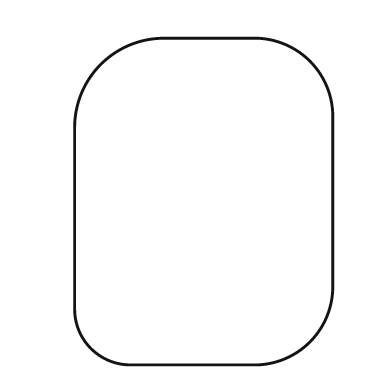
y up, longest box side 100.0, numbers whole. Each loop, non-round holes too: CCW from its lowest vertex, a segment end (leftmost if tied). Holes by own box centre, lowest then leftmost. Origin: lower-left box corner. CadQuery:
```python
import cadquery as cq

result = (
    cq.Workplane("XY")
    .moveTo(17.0, 0.0)
    .lineTo(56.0, 0.0)
    .threePointArc((72.0, 7.0), (79.0, 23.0))
    .lineTo(79.0, 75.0)
    .threePointArc((72.0, 93.0), (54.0, 100.0))
    .lineTo(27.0, 100.0)
    .threePointArc((8.0, 92.0), (0.0, 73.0))
    .lineTo(0.0, 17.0)
    .threePointArc((5.0, 5.0), (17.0, 0.0))
    .close()
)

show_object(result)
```